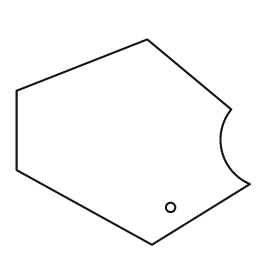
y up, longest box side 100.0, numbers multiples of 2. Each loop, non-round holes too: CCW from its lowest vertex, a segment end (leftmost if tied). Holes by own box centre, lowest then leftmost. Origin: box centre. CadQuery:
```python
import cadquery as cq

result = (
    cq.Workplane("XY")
    .moveTo(8.0, -44.0)
    .lineTo(50.0, -18.0)
    .threePointArc((38.0, -4.0), (42.0, 14.0))
    .lineTo(6.0, 44.0)
    .lineTo(-50.0, 22.0)
    .lineTo(-50.0, -12.0)
    .close()
    .moveTo(16.0, -28.0)
    .circle(2.0)
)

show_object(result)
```